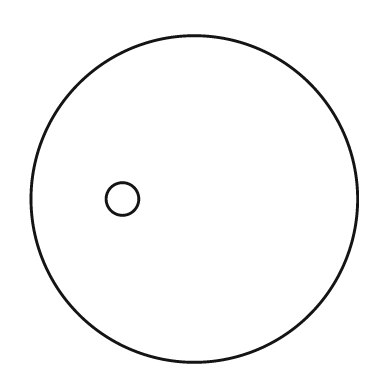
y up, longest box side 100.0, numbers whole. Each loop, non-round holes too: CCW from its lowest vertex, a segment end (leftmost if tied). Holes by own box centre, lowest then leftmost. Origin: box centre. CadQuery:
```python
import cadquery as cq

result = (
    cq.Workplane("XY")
    .moveTo(0.0, 0.0)
    .circle(50.0)
    .moveTo(-22.0, 0.0)
    .circle(5.0)
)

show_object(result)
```